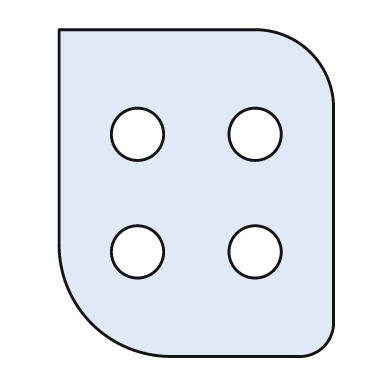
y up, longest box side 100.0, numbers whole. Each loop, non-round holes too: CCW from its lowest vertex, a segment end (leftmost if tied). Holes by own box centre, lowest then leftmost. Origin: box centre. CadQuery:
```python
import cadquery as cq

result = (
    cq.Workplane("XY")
    .moveTo(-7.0, -50.0)
    .lineTo(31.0, -50.0)
    .threePointArc((39.0, -47.0), (42.0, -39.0))
    .lineTo(42.0, 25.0)
    .threePointArc((35.0, 43.0), (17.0, 50.0))
    .lineTo(-42.0, 50.0)
    .lineTo(-42.0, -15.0)
    .threePointArc((-32.0, -40.0), (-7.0, -50.0))
    .close()
    .moveTo(-18.0, -18.0)
    .circle(8.0)
    .moveTo(18.0, -18.0)
    .circle(8.0)
    .moveTo(-18.0, 18.0)
    .circle(8.0)
    .moveTo(18.0, 18.0)
    .circle(8.0)
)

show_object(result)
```